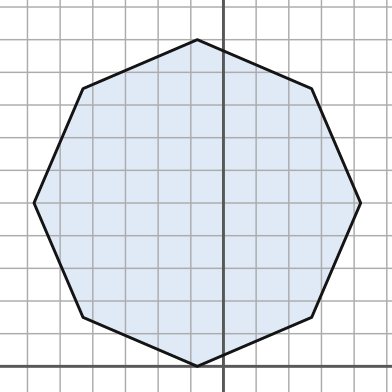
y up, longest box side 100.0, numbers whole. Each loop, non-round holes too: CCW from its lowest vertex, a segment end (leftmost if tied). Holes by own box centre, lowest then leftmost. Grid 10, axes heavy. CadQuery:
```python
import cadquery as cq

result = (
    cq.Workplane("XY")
    .moveTo(-8.0, 0.0)
    .lineTo(27.0, 15.0)
    .lineTo(42.0, 50.0)
    .lineTo(27.0, 85.0)
    .lineTo(-8.0, 100.0)
    .lineTo(-43.0, 85.0)
    .lineTo(-58.0, 50.0)
    .lineTo(-43.0, 15.0)
    .close()
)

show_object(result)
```